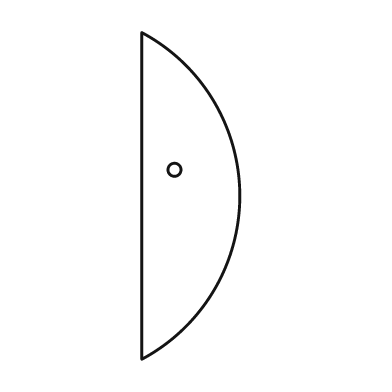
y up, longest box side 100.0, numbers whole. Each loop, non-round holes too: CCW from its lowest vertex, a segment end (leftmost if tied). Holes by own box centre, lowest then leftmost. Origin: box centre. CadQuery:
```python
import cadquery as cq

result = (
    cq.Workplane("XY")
    .moveTo(-15.0, -50.0)
    .threePointArc((15.0, 0.0), (-15.0, 50.0))
    .close()
    .moveTo(-5.0, 8.0)
    .circle(2.0)
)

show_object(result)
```